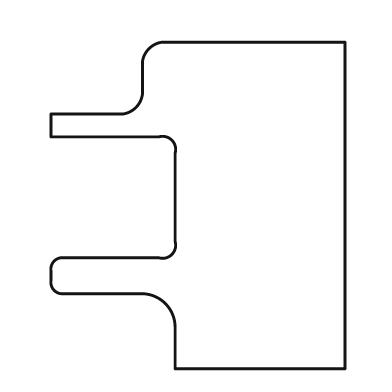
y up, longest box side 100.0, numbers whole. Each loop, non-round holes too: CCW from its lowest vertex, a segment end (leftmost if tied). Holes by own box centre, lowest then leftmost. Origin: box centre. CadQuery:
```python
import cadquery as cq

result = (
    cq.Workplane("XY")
    .moveTo(-7.0, -50.0)
    .lineTo(45.0, -50.0)
    .lineTo(45.0, 50.0)
    .lineTo(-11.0, 50.0)
    .threePointArc((-15.0, 48.0), (-17.0, 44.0))
    .lineTo(-17.0, 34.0)
    .threePointArc((-19.0, 30.0), (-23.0, 28.0))
    .lineTo(-45.0, 28.0)
    .lineTo(-45.0, 21.0)
    .lineTo(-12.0, 21.0)
    .threePointArc((-8.0, 20.0), (-7.0, 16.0))
    .lineTo(-7.0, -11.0)
    .threePointArc((-8.0, -15.0), (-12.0, -16.0))
    .lineTo(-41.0, -16.0)
    .threePointArc((-44.0, -17.0), (-45.0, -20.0))
    .lineTo(-45.0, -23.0)
    .threePointArc((-44.0, -26.0), (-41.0, -27.0))
    .lineTo(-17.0, -27.0)
    .threePointArc((-10.0, -30.0), (-7.0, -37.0))
    .close()
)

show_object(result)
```